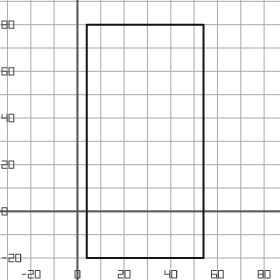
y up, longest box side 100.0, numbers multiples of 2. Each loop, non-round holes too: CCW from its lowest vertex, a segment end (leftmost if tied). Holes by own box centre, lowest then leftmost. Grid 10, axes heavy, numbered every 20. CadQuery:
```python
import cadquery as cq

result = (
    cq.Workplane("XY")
    .moveTo(4.0, -20.0)
    .lineTo(54.0, -20.0)
    .lineTo(54.0, 80.0)
    .lineTo(4.0, 80.0)
    .close()
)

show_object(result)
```